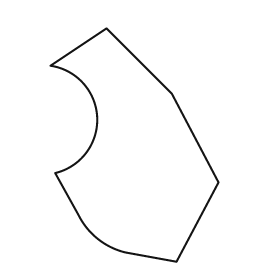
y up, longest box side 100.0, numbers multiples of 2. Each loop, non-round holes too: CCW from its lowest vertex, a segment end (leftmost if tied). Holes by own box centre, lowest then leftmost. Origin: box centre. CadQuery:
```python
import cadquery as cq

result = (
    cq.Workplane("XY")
    .moveTo(18.0, -50.0)
    .lineTo(36.0, -16.0)
    .lineTo(16.0, 22.0)
    .lineTo(-12.0, 50.0)
    .lineTo(-36.0, 34.0)
    .threePointArc((-16.0, 12.0), (-34.0, -12.0))
    .lineTo(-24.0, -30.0)
    .threePointArc((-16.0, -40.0), (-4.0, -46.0))
    .close()
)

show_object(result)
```